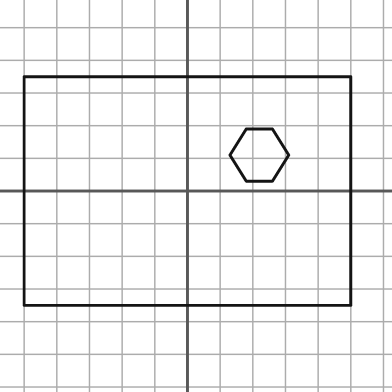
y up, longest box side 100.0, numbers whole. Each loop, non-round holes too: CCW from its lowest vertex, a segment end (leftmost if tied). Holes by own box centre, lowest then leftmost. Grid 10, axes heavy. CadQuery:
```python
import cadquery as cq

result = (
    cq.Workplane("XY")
    .moveTo(-50.0, -35.0)
    .lineTo(50.0, -35.0)
    .lineTo(50.0, 35.0)
    .lineTo(-50.0, 35.0)
    .close()
    .moveTo(18.0, 3.0)
    .lineTo(26.0, 3.0)
    .lineTo(31.0, 11.0)
    .lineTo(26.0, 19.0)
    .lineTo(18.0, 19.0)
    .lineTo(13.0, 11.0)
    .close()
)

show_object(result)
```